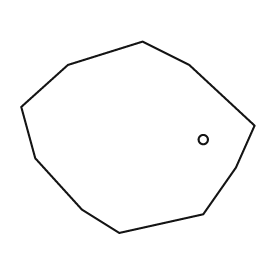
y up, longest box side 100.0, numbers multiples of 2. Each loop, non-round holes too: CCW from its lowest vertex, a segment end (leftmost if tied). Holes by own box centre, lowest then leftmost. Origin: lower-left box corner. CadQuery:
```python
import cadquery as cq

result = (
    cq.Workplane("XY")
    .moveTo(42.0, 0.0)
    .lineTo(78.0, 8.0)
    .lineTo(92.0, 28.0)
    .lineTo(100.0, 46.0)
    .lineTo(72.0, 72.0)
    .lineTo(52.0, 82.0)
    .lineTo(20.0, 72.0)
    .lineTo(0.0, 54.0)
    .lineTo(6.0, 32.0)
    .lineTo(26.0, 10.0)
    .close()
    .moveTo(78.0, 40.0)
    .circle(2.0)
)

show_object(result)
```